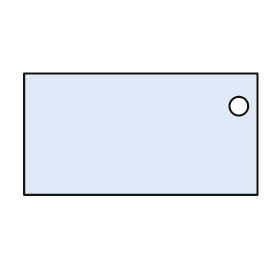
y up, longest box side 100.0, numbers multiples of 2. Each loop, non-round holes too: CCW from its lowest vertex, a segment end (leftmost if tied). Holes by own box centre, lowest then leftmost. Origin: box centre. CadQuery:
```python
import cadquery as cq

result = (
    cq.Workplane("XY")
    .moveTo(-50.0, -26.0)
    .lineTo(50.0, -26.0)
    .lineTo(50.0, 26.0)
    .lineTo(-50.0, 26.0)
    .close()
    .moveTo(42.0, 12.0)
    .circle(4.0)
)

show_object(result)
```